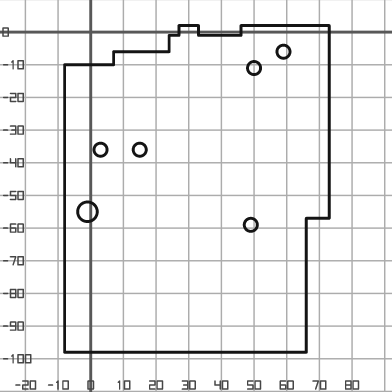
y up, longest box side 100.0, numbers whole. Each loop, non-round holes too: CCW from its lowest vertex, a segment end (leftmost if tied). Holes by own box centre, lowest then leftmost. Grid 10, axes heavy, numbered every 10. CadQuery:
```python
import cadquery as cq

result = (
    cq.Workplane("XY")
    .moveTo(-8.0, -98.0)
    .lineTo(66.0, -98.0)
    .lineTo(66.0, -57.0)
    .lineTo(73.0, -57.0)
    .lineTo(73.0, 2.0)
    .lineTo(46.0, 2.0)
    .lineTo(46.0, -1.0)
    .lineTo(33.0, -1.0)
    .lineTo(33.0, 2.0)
    .lineTo(27.0, 2.0)
    .lineTo(27.0, -1.0)
    .lineTo(24.0, -1.0)
    .lineTo(24.0, -6.0)
    .lineTo(7.0, -6.0)
    .lineTo(7.0, -10.0)
    .lineTo(-8.0, -10.0)
    .close()
    .moveTo(49.0, -59.0)
    .circle(2.0)
    .moveTo(-1.0, -55.0)
    .circle(3.0)
    .moveTo(3.0, -36.0)
    .circle(2.0)
    .moveTo(15.0, -36.0)
    .circle(2.0)
    .moveTo(50.0, -11.0)
    .circle(2.0)
    .moveTo(59.0, -6.0)
    .circle(2.0)
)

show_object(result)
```